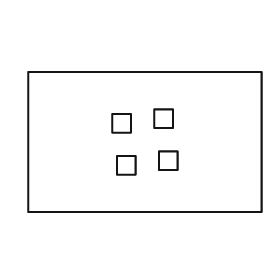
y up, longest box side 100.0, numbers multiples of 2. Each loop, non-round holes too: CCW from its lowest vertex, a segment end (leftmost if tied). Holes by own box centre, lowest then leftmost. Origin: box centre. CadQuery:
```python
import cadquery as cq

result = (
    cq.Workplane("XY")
    .moveTo(-50.0, -30.0)
    .lineTo(50.0, -30.0)
    .lineTo(50.0, 30.0)
    .lineTo(-50.0, 30.0)
    .close()
    .moveTo(-12.0, -14.0)
    .lineTo(-4.0, -14.0)
    .lineTo(-4.0, -6.0)
    .lineTo(-12.0, -6.0)
    .close()
    .moveTo(6.0, -12.0)
    .lineTo(14.0, -12.0)
    .lineTo(14.0, -4.0)
    .lineTo(6.0, -4.0)
    .close()
    .moveTo(-14.0, 4.0)
    .lineTo(-6.0, 4.0)
    .lineTo(-6.0, 12.0)
    .lineTo(-14.0, 12.0)
    .close()
    .moveTo(4.0, 6.0)
    .lineTo(12.0, 6.0)
    .lineTo(12.0, 14.0)
    .lineTo(4.0, 14.0)
    .close()
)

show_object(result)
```